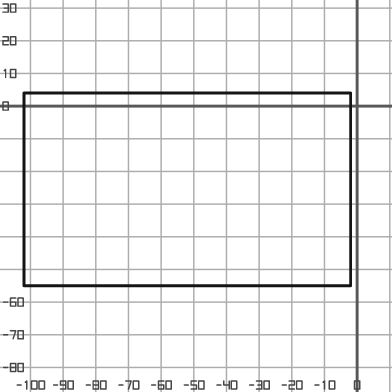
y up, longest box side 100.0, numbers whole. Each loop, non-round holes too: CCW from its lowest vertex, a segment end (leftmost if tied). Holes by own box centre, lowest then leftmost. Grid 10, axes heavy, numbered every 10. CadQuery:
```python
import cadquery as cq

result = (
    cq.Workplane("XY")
    .moveTo(-102.0, -55.0)
    .lineTo(-2.0, -55.0)
    .lineTo(-2.0, 4.0)
    .lineTo(-102.0, 4.0)
    .close()
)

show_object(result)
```